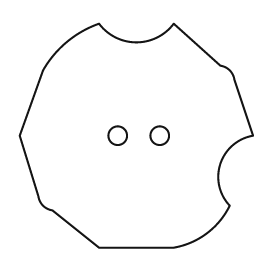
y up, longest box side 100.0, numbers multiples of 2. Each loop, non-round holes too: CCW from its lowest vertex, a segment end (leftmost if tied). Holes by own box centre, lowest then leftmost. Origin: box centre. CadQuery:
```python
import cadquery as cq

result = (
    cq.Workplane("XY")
    .moveTo(-16.0, -48.0)
    .lineTo(16.0, -48.0)
    .threePointArc((30.0, -42.0), (40.0, -30.0))
    .threePointArc((36.0, -12.0), (50.0, 0.0))
    .lineTo(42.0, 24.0)
    .threePointArc((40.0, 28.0), (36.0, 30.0))
    .lineTo(16.0, 48.0)
    .threePointArc((0.0, 40.0), (-16.0, 48.0))
    .threePointArc((-30.0, 40.0), (-40.0, 28.0))
    .lineTo(-50.0, 0.0)
    .lineTo(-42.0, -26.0)
    .threePointArc((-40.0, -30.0), (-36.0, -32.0))
    .close()
    .moveTo(-8.0, 0.0)
    .circle(4.0)
    .moveTo(10.0, 0.0)
    .circle(4.0)
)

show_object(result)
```